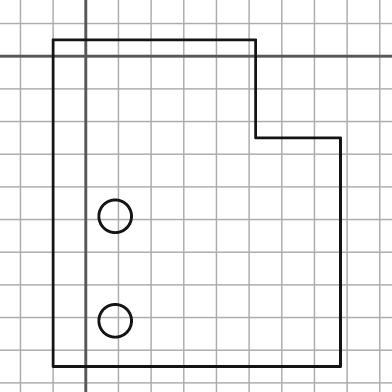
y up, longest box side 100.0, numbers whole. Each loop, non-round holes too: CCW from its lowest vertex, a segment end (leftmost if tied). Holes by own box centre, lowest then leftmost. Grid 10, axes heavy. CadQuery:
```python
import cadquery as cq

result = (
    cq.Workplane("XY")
    .moveTo(-10.0, -95.0)
    .lineTo(78.0, -95.0)
    .lineTo(78.0, -25.0)
    .lineTo(52.0, -25.0)
    .lineTo(52.0, 5.0)
    .lineTo(-10.0, 5.0)
    .close()
    .moveTo(9.0, -81.0)
    .circle(5.0)
    .moveTo(9.0, -49.0)
    .circle(5.0)
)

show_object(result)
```